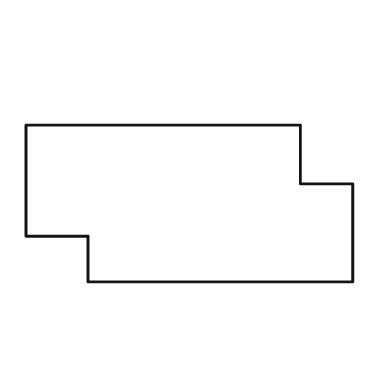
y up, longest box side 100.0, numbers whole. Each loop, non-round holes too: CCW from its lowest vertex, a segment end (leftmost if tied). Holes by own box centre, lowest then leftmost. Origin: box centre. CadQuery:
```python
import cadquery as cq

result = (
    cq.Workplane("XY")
    .moveTo(-31.0, -24.0)
    .lineTo(50.0, -24.0)
    .lineTo(50.0, 6.0)
    .lineTo(34.0, 6.0)
    .lineTo(34.0, 24.0)
    .lineTo(-50.0, 24.0)
    .lineTo(-50.0, -10.0)
    .lineTo(-31.0, -10.0)
    .close()
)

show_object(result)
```